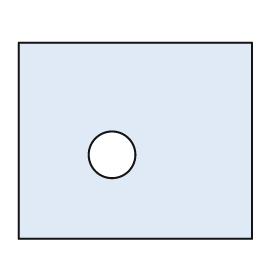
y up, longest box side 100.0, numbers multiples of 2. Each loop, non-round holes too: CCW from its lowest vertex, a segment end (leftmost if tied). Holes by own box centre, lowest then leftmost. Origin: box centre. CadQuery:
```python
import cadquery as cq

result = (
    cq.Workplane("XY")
    .moveTo(-50.0, -42.0)
    .lineTo(50.0, -42.0)
    .lineTo(50.0, 42.0)
    .lineTo(-50.0, 42.0)
    .close()
    .moveTo(-10.0, -6.0)
    .circle(10.0)
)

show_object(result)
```